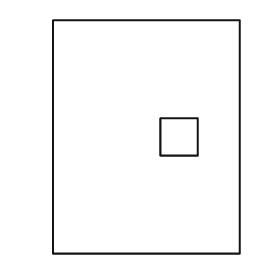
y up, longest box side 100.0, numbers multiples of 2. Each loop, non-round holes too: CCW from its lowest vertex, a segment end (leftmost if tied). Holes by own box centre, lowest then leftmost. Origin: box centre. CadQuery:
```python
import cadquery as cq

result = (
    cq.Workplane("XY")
    .moveTo(-40.0, -50.0)
    .lineTo(40.0, -50.0)
    .lineTo(40.0, 50.0)
    .lineTo(-40.0, 50.0)
    .close()
    .moveTo(6.0, -8.0)
    .lineTo(22.0, -8.0)
    .lineTo(22.0, 8.0)
    .lineTo(6.0, 8.0)
    .close()
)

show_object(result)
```